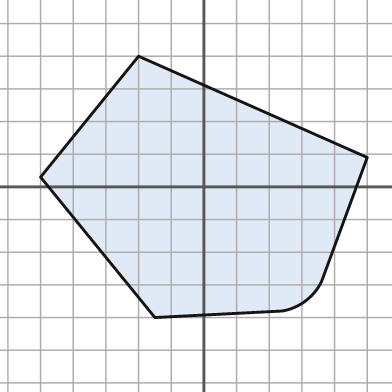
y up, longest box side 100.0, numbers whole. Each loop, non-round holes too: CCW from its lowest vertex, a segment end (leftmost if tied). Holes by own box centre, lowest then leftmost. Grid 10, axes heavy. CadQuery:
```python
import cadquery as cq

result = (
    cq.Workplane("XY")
    .moveTo(-15.0, -40.0)
    .lineTo(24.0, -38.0)
    .threePointArc((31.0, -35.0), (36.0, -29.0))
    .lineTo(50.0, 9.0)
    .lineTo(-20.0, 40.0)
    .lineTo(-50.0, 3.0)
    .close()
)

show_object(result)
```